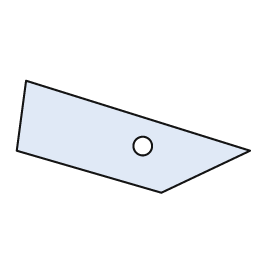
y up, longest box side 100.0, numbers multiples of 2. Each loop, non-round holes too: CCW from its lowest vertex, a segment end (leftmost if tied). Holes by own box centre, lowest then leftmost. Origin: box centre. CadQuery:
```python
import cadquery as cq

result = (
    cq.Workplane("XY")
    .moveTo(12.0, -24.0)
    .lineTo(50.0, -6.0)
    .lineTo(-46.0, 24.0)
    .lineTo(-50.0, -6.0)
    .close()
    .moveTo(4.0, -4.0)
    .circle(4.0)
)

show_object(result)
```